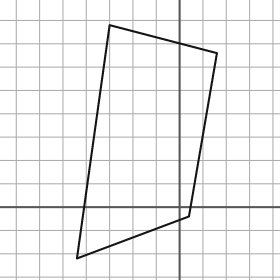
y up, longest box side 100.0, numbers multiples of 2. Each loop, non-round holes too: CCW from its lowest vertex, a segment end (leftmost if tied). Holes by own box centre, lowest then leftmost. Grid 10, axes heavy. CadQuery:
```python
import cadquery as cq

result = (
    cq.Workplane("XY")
    .moveTo(-44.0, -22.0)
    .lineTo(4.0, -4.0)
    .lineTo(16.0, 66.0)
    .lineTo(-30.0, 78.0)
    .close()
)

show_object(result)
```